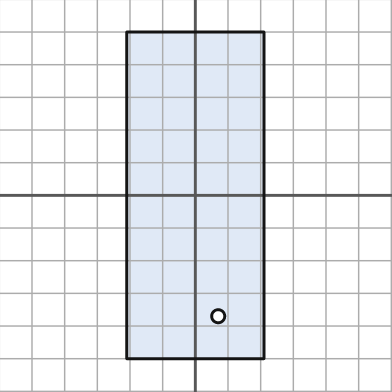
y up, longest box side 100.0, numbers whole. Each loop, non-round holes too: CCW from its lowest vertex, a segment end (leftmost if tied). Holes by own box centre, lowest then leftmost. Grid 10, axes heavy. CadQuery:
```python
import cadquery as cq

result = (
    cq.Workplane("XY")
    .moveTo(-21.0, -50.0)
    .lineTo(21.0, -50.0)
    .lineTo(21.0, 50.0)
    .lineTo(-21.0, 50.0)
    .close()
    .moveTo(7.0, -37.0)
    .circle(2.0)
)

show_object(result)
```